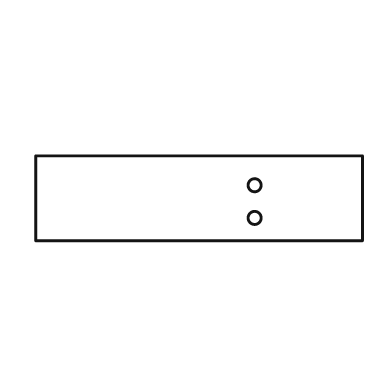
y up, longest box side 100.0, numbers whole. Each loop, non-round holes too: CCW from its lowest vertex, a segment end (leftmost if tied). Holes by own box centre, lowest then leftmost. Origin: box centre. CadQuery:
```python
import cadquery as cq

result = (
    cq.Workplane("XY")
    .moveTo(-50.0, -13.0)
    .lineTo(50.0, -13.0)
    .lineTo(50.0, 13.0)
    .lineTo(-50.0, 13.0)
    .close()
    .moveTo(17.0, -6.0)
    .circle(2.0)
    .moveTo(17.0, 4.0)
    .circle(2.0)
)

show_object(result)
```